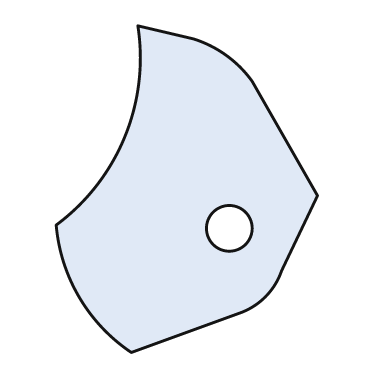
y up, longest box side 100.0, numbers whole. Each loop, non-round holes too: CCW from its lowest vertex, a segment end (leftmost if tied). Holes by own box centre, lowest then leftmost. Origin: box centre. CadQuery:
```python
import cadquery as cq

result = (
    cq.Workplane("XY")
    .moveTo(-17.0, -50.0)
    .lineTo(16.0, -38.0)
    .threePointArc((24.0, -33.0), (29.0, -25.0))
    .lineTo(40.0, -2.0)
    .lineTo(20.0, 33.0)
    .threePointArc((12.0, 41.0), (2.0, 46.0))
    .lineTo(-15.0, 50.0)
    .threePointArc((-19.0, 16.0), (-40.0, -11.0))
    .threePointArc((-33.0, -33.0), (-17.0, -50.0))
    .close()
    .moveTo(13.0, -12.0)
    .circle(7.0)
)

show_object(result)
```